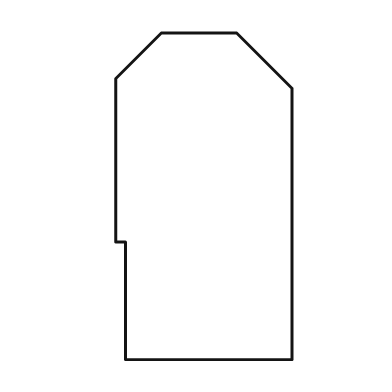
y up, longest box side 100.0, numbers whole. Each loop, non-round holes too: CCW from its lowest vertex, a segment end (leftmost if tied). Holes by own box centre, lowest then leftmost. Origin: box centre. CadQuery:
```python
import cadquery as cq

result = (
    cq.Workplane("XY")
    .moveTo(-24.0, -50.0)
    .lineTo(27.0, -50.0)
    .lineTo(27.0, 33.0)
    .lineTo(10.0, 50.0)
    .lineTo(-13.0, 50.0)
    .lineTo(-27.0, 36.0)
    .lineTo(-27.0, -14.0)
    .lineTo(-24.0, -14.0)
    .close()
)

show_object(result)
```